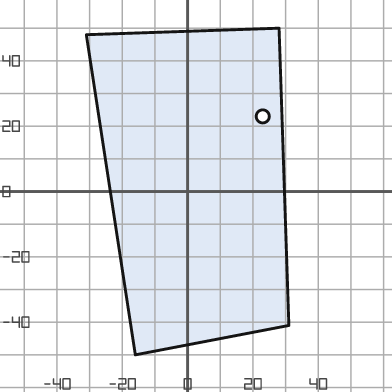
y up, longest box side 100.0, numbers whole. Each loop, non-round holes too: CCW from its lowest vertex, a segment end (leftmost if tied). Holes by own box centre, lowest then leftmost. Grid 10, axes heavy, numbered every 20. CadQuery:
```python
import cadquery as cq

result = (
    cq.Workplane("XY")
    .moveTo(-16.0, -50.0)
    .lineTo(31.0, -41.0)
    .lineTo(28.0, 50.0)
    .lineTo(-31.0, 48.0)
    .close()
    .moveTo(23.0, 23.0)
    .circle(2.0)
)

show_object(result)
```